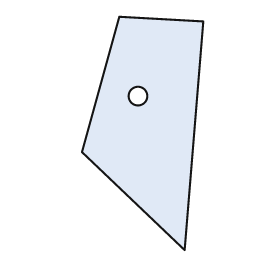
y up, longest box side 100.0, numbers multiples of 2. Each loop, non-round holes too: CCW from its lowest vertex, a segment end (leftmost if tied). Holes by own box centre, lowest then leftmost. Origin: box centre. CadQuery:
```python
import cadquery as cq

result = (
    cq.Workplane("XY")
    .moveTo(18.0, -50.0)
    .lineTo(26.0, 48.0)
    .lineTo(-10.0, 50.0)
    .lineTo(-26.0, -8.0)
    .close()
    .moveTo(-2.0, 16.0)
    .circle(4.0)
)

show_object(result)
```